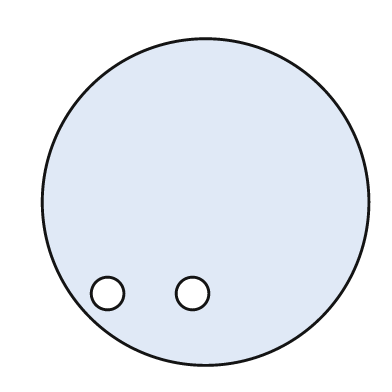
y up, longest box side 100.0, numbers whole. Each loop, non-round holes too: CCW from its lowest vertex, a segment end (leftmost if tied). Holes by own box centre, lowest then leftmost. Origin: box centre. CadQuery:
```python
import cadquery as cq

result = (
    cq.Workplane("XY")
    .moveTo(0.0, 0.0)
    .circle(50.0)
    .moveTo(-30.0, -28.0)
    .circle(5.0)
    .moveTo(-4.0, -28.0)
    .circle(5.0)
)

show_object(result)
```